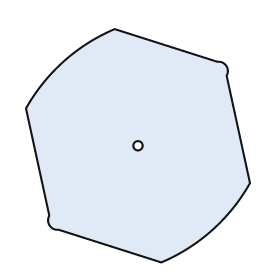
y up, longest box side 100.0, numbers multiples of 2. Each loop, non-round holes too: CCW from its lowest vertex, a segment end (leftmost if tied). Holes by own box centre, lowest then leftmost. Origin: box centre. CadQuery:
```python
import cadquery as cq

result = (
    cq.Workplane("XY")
    .moveTo(10.0, -50.0)
    .threePointArc((32.0, -36.0), (48.0, -16.0))
    .lineTo(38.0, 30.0)
    .threePointArc((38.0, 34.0), (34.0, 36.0))
    .lineTo(-10.0, 50.0)
    .threePointArc((-32.0, 36.0), (-48.0, 16.0))
    .lineTo(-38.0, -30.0)
    .threePointArc((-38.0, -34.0), (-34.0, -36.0))
    .close()
    .moveTo(0.0, 0.0)
    .circle(2.0)
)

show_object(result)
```